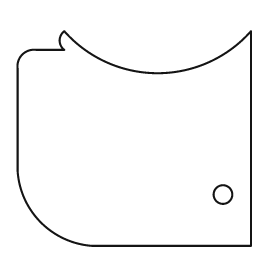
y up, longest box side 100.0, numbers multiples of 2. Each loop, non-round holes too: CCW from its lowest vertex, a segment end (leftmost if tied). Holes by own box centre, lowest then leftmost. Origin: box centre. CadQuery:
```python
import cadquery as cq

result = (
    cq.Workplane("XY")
    .moveTo(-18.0, -46.0)
    .lineTo(50.0, -46.0)
    .lineTo(50.0, 46.0)
    .threePointArc((10.0, 28.0), (-30.0, 46.0))
    .threePointArc((-32.0, 42.0), (-30.0, 38.0))
    .lineTo(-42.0, 38.0)
    .threePointArc((-48.0, 36.0), (-50.0, 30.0))
    .lineTo(-50.0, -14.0)
    .threePointArc((-40.0, -36.0), (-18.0, -46.0))
    .close()
    .moveTo(38.0, -24.0)
    .circle(4.0)
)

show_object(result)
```